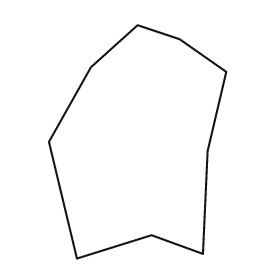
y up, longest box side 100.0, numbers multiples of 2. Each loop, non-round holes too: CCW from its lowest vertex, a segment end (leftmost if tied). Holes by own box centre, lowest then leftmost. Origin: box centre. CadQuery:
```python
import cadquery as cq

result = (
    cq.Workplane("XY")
    .moveTo(-26.0, -50.0)
    .lineTo(6.0, -40.0)
    .lineTo(28.0, -48.0)
    .lineTo(30.0, -4.0)
    .lineTo(38.0, 30.0)
    .lineTo(18.0, 44.0)
    .lineTo(0.0, 50.0)
    .lineTo(-20.0, 32.0)
    .lineTo(-38.0, 0.0)
    .close()
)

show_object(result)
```